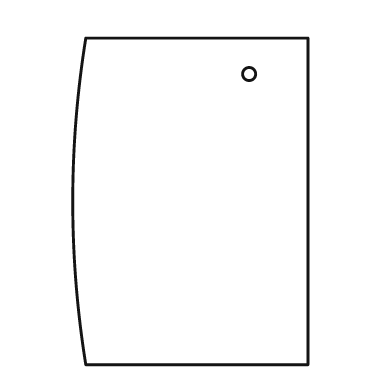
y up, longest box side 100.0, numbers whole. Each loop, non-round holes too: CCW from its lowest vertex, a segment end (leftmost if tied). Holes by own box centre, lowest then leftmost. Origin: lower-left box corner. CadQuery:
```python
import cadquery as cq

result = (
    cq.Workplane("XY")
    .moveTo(4.0, 0.0)
    .lineTo(72.0, 0.0)
    .lineTo(72.0, 100.0)
    .lineTo(4.0, 100.0)
    .threePointArc((0.0, 50.0), (4.0, 0.0))
    .close()
    .moveTo(54.0, 89.0)
    .circle(2.0)
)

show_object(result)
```